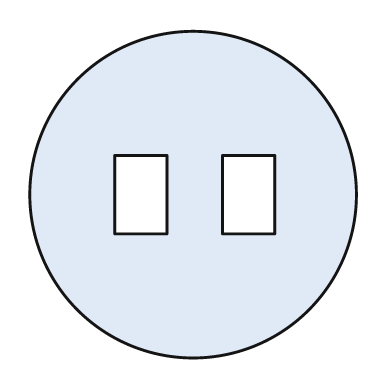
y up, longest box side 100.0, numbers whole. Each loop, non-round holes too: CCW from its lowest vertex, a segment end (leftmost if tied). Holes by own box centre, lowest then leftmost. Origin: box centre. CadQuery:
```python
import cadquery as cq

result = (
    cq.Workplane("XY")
    .moveTo(0.0, 0.0)
    .circle(50.0)
    .moveTo(-24.0, -12.0)
    .lineTo(-8.0, -12.0)
    .lineTo(-8.0, 12.0)
    .lineTo(-24.0, 12.0)
    .close()
    .moveTo(9.0, -12.0)
    .lineTo(25.0, -12.0)
    .lineTo(25.0, 12.0)
    .lineTo(9.0, 12.0)
    .close()
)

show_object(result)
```